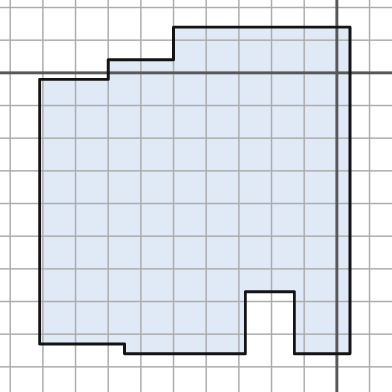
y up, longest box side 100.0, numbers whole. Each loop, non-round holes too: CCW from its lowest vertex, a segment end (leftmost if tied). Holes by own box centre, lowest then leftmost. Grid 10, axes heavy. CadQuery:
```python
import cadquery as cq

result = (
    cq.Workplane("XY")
    .moveTo(-65.0, -86.0)
    .lineTo(-28.0, -86.0)
    .lineTo(-28.0, -67.0)
    .lineTo(-13.0, -67.0)
    .lineTo(-13.0, -86.0)
    .lineTo(4.0, -86.0)
    .lineTo(4.0, 14.0)
    .lineTo(-50.0, 14.0)
    .lineTo(-50.0, 4.0)
    .lineTo(-70.0, 4.0)
    .lineTo(-70.0, -2.0)
    .lineTo(-91.0, -2.0)
    .lineTo(-91.0, -83.0)
    .lineTo(-65.0, -83.0)
    .close()
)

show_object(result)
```